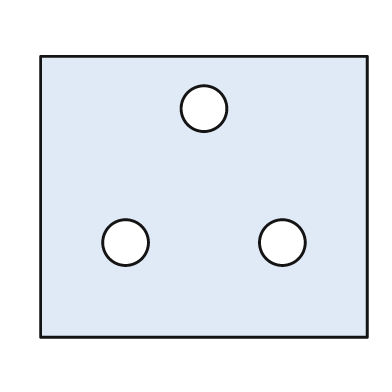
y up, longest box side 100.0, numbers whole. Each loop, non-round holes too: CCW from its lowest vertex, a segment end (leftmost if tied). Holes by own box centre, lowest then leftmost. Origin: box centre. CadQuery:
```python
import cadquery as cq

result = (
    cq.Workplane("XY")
    .moveTo(-50.0, -43.0)
    .lineTo(50.0, -43.0)
    .lineTo(50.0, 43.0)
    .lineTo(-50.0, 43.0)
    .close()
    .moveTo(-24.0, -14.0)
    .circle(7.0)
    .moveTo(24.0, -14.0)
    .circle(7.0)
    .moveTo(0.0, 27.0)
    .circle(7.0)
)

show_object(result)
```